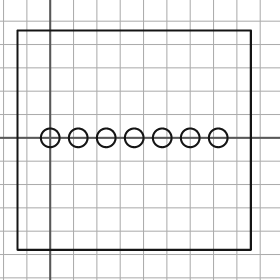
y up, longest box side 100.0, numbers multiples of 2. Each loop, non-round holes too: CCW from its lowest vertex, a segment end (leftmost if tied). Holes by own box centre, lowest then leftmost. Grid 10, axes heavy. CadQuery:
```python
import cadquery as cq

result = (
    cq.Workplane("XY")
    .moveTo(-14.0, -48.0)
    .lineTo(86.0, -48.0)
    .lineTo(86.0, 46.0)
    .lineTo(-14.0, 46.0)
    .close()
    .moveTo(0.0, 0.0)
    .circle(4.0)
    .moveTo(12.0, 0.0)
    .circle(4.0)
    .moveTo(24.0, 0.0)
    .circle(4.0)
    .moveTo(36.0, 0.0)
    .circle(4.0)
    .moveTo(48.0, 0.0)
    .circle(4.0)
    .moveTo(60.0, 0.0)
    .circle(4.0)
    .moveTo(72.0, 0.0)
    .circle(4.0)
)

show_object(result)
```